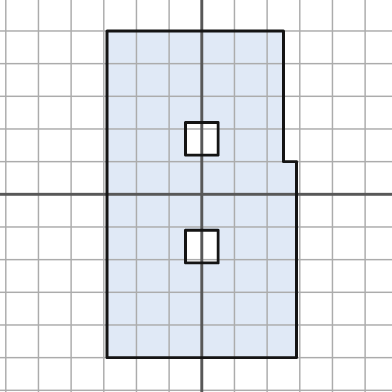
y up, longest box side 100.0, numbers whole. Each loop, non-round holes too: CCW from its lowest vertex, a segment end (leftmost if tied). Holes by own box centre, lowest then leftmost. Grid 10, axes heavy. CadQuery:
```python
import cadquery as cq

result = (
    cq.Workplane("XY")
    .moveTo(-29.0, -50.0)
    .lineTo(29.0, -50.0)
    .lineTo(29.0, 10.0)
    .lineTo(25.0, 10.0)
    .lineTo(25.0, 50.0)
    .lineTo(-29.0, 50.0)
    .close()
    .moveTo(-5.0, -21.0)
    .lineTo(5.0, -21.0)
    .lineTo(5.0, -11.0)
    .lineTo(-5.0, -11.0)
    .close()
    .moveTo(-5.0, 12.0)
    .lineTo(5.0, 12.0)
    .lineTo(5.0, 22.0)
    .lineTo(-5.0, 22.0)
    .close()
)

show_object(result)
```